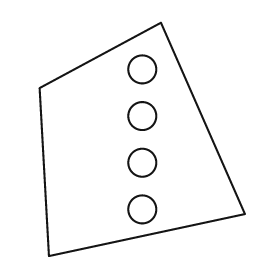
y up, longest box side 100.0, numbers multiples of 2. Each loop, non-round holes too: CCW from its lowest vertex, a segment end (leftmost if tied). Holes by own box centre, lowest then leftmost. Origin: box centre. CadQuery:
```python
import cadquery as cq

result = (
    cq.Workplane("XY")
    .moveTo(-40.0, -50.0)
    .lineTo(44.0, -32.0)
    .lineTo(8.0, 50.0)
    .lineTo(-44.0, 22.0)
    .close()
    .moveTo(0.0, -30.0)
    .circle(6.0)
    .moveTo(0.0, -10.0)
    .circle(6.0)
    .moveTo(0.0, 10.0)
    .circle(6.0)
    .moveTo(0.0, 30.0)
    .circle(6.0)
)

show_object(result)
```